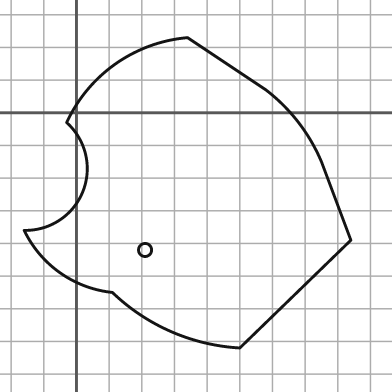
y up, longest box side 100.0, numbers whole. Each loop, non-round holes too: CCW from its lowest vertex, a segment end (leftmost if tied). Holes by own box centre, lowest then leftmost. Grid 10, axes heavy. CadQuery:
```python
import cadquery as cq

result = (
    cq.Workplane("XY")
    .moveTo(50.0, -72.0)
    .lineTo(84.0, -39.0)
    .lineTo(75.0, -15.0)
    .threePointArc((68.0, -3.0), (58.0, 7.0))
    .lineTo(34.0, 23.0)
    .threePointArc((12.0, 15.0), (-3.0, -3.0))
    .threePointArc((2.0, -24.0), (-16.0, -36.0))
    .threePointArc((-5.0, -49.0), (11.0, -55.0))
    .threePointArc((29.0, -67.0), (50.0, -72.0))
    .close()
    .moveTo(21.0, -42.0)
    .circle(2.0)
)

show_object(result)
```